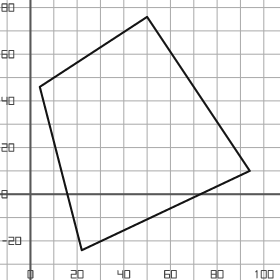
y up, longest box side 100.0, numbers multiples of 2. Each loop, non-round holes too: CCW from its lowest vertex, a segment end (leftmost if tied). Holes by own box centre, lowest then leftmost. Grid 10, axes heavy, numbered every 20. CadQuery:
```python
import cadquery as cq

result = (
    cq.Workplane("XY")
    .moveTo(22.0, -24.0)
    .lineTo(94.0, 10.0)
    .lineTo(50.0, 76.0)
    .lineTo(4.0, 46.0)
    .close()
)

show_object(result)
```